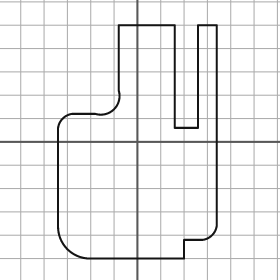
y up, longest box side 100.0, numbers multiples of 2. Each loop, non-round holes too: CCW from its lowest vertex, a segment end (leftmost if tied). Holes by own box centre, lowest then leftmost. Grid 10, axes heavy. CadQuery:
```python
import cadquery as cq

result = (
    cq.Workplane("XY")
    .moveTo(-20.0, -50.0)
    .lineTo(20.0, -50.0)
    .lineTo(20.0, -42.0)
    .lineTo(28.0, -42.0)
    .threePointArc((32.0, -40.0), (34.0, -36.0))
    .lineTo(34.0, 50.0)
    .lineTo(26.0, 50.0)
    .lineTo(26.0, 6.0)
    .lineTo(16.0, 6.0)
    .lineTo(16.0, 50.0)
    .lineTo(-8.0, 50.0)
    .lineTo(-8.0, 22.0)
    .threePointArc((-10.0, 14.0), (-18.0, 12.0))
    .lineTo(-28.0, 12.0)
    .threePointArc((-32.0, 10.0), (-34.0, 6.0))
    .lineTo(-34.0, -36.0)
    .threePointArc((-30.0, -46.0), (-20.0, -50.0))
    .close()
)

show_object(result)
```